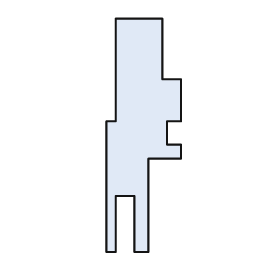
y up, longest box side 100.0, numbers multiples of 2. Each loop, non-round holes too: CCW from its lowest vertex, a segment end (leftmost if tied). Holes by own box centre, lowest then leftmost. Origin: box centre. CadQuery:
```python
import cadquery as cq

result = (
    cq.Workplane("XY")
    .moveTo(-16.0, -50.0)
    .lineTo(-12.0, -50.0)
    .lineTo(-12.0, -26.0)
    .lineTo(-4.0, -26.0)
    .lineTo(-4.0, -50.0)
    .lineTo(2.0, -50.0)
    .lineTo(2.0, -10.0)
    .lineTo(16.0, -10.0)
    .lineTo(16.0, -4.0)
    .lineTo(10.0, -4.0)
    .lineTo(10.0, 6.0)
    .lineTo(16.0, 6.0)
    .lineTo(16.0, 24.0)
    .lineTo(8.0, 24.0)
    .lineTo(8.0, 50.0)
    .lineTo(-12.0, 50.0)
    .lineTo(-12.0, 6.0)
    .lineTo(-16.0, 6.0)
    .close()
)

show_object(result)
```